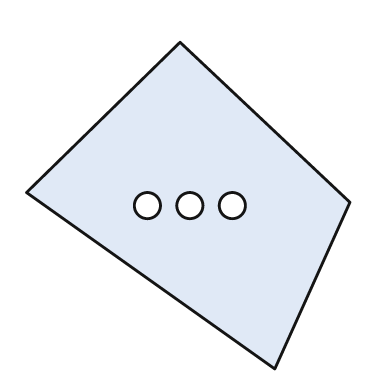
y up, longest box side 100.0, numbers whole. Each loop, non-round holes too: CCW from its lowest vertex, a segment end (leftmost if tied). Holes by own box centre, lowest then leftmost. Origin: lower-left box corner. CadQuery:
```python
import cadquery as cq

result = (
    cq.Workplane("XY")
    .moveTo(76.0, 0.0)
    .lineTo(99.0, 51.0)
    .lineTo(47.0, 100.0)
    .lineTo(0.0, 54.0)
    .close()
    .moveTo(37.0, 50.0)
    .circle(4.0)
    .moveTo(50.0, 50.0)
    .circle(4.0)
    .moveTo(63.0, 50.0)
    .circle(4.0)
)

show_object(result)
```